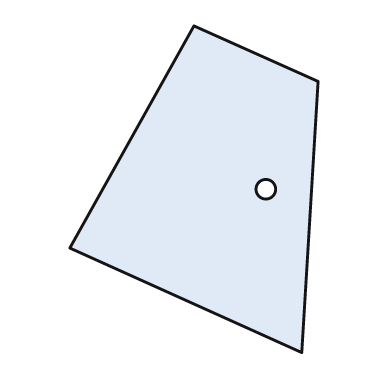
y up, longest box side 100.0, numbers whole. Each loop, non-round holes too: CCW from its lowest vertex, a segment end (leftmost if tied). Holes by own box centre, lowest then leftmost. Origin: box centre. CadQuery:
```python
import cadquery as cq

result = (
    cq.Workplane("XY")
    .moveTo(33.0, -50.0)
    .lineTo(38.0, 33.0)
    .lineTo(0.0, 50.0)
    .lineTo(-38.0, -18.0)
    .close()
    .moveTo(22.0, 0.0)
    .circle(3.0)
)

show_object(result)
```